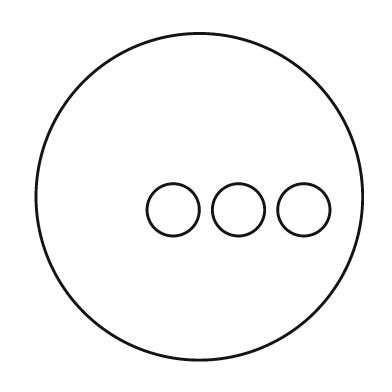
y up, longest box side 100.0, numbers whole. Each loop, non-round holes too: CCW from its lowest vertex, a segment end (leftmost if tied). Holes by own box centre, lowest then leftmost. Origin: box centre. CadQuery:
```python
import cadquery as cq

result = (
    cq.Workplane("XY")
    .moveTo(0.0, 0.0)
    .circle(50.0)
    .moveTo(-8.0, -4.0)
    .circle(8.0)
    .moveTo(12.0, -4.0)
    .circle(8.0)
    .moveTo(32.0, -4.0)
    .circle(8.0)
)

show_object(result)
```